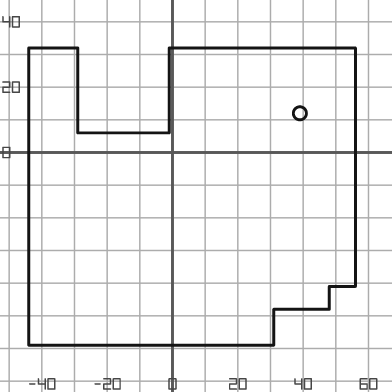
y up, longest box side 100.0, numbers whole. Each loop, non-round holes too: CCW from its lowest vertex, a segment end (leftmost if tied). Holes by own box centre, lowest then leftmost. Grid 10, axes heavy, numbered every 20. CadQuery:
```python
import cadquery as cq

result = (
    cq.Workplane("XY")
    .moveTo(-44.0, -59.0)
    .lineTo(31.0, -59.0)
    .lineTo(31.0, -48.0)
    .lineTo(48.0, -48.0)
    .lineTo(48.0, -41.0)
    .lineTo(56.0, -41.0)
    .lineTo(56.0, 32.0)
    .lineTo(-1.0, 32.0)
    .lineTo(-1.0, 6.0)
    .lineTo(-29.0, 6.0)
    .lineTo(-29.0, 32.0)
    .lineTo(-44.0, 32.0)
    .close()
    .moveTo(39.0, 12.0)
    .circle(2.0)
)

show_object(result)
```